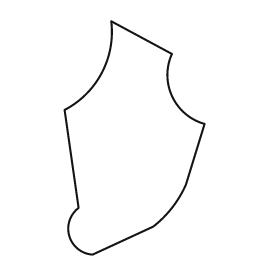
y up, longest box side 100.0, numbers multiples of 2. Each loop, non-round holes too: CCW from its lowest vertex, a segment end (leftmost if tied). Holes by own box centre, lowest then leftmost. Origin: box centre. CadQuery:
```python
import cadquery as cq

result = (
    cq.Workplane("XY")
    .moveTo(-18.0, -50.0)
    .lineTo(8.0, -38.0)
    .threePointArc((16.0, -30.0), (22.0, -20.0))
    .lineTo(30.0, 6.0)
    .threePointArc((16.0, 18.0), (16.0, 36.0))
    .lineTo(-10.0, 50.0)
    .threePointArc((-14.0, 28.0), (-30.0, 12.0))
    .lineTo(-24.0, -30.0)
    .threePointArc((-28.0, -42.0), (-18.0, -50.0))
    .close()
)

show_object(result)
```